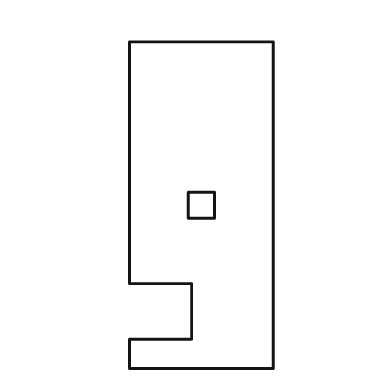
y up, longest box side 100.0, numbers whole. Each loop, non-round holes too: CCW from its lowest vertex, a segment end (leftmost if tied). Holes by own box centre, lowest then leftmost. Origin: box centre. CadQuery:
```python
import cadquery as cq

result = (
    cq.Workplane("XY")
    .moveTo(-22.0, -50.0)
    .lineTo(22.0, -50.0)
    .lineTo(22.0, 50.0)
    .lineTo(-22.0, 50.0)
    .lineTo(-22.0, -24.0)
    .lineTo(-3.0, -24.0)
    .lineTo(-3.0, -41.0)
    .lineTo(-22.0, -41.0)
    .close()
    .moveTo(-4.0, -4.0)
    .lineTo(4.0, -4.0)
    .lineTo(4.0, 4.0)
    .lineTo(-4.0, 4.0)
    .close()
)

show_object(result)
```